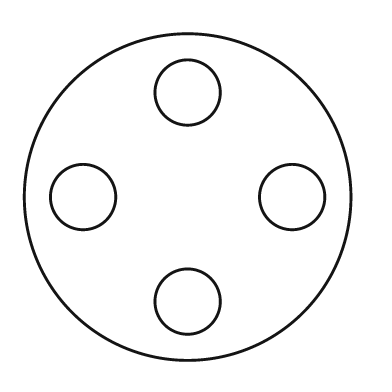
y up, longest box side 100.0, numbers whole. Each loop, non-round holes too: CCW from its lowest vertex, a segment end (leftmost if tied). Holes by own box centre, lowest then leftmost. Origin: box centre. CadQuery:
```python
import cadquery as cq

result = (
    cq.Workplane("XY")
    .moveTo(0.0, 0.0)
    .circle(50.0)
    .moveTo(0.0, -32.0)
    .circle(10.0)
    .moveTo(-32.0, 0.0)
    .circle(10.0)
    .moveTo(32.0, 0.0)
    .circle(10.0)
    .moveTo(0.0, 32.0)
    .circle(10.0)
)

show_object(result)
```